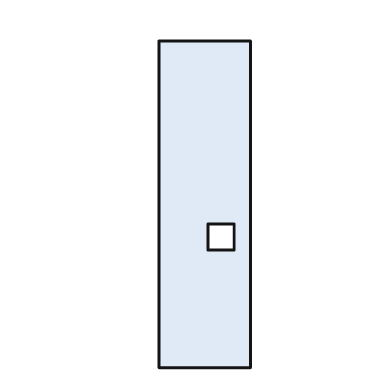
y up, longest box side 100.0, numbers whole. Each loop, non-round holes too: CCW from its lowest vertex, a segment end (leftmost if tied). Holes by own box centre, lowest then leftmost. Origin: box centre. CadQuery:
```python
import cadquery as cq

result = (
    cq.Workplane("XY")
    .moveTo(-14.0, -50.0)
    .lineTo(14.0, -50.0)
    .lineTo(14.0, 50.0)
    .lineTo(-14.0, 50.0)
    .close()
    .moveTo(1.0, -14.0)
    .lineTo(9.0, -14.0)
    .lineTo(9.0, -6.0)
    .lineTo(1.0, -6.0)
    .close()
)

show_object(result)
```